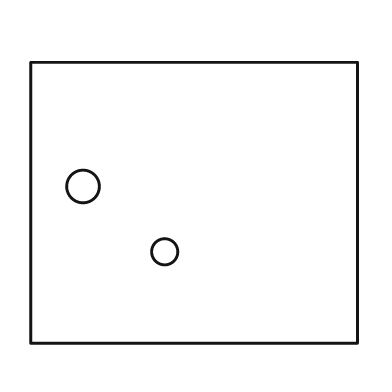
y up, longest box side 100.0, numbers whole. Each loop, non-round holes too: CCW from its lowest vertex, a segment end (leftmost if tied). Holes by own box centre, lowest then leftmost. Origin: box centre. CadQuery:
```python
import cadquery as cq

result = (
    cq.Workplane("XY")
    .moveTo(-50.0, -43.0)
    .lineTo(50.0, -43.0)
    .lineTo(50.0, 43.0)
    .lineTo(-50.0, 43.0)
    .close()
    .moveTo(-9.0, -15.0)
    .circle(4.0)
    .moveTo(-34.0, 5.0)
    .circle(5.0)
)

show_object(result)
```